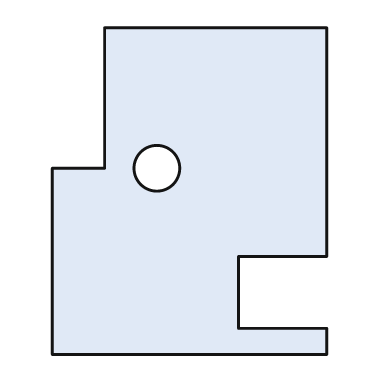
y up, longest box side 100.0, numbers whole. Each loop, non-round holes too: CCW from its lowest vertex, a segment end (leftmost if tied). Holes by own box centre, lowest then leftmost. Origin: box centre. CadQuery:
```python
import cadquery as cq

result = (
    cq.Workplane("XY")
    .moveTo(-42.0, -50.0)
    .lineTo(42.0, -50.0)
    .lineTo(42.0, -42.0)
    .lineTo(15.0, -42.0)
    .lineTo(15.0, -20.0)
    .lineTo(42.0, -20.0)
    .lineTo(42.0, 50.0)
    .lineTo(-26.0, 50.0)
    .lineTo(-26.0, 7.0)
    .lineTo(-42.0, 7.0)
    .close()
    .moveTo(-10.0, 7.0)
    .circle(7.0)
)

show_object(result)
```